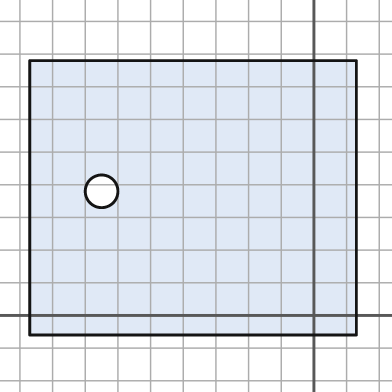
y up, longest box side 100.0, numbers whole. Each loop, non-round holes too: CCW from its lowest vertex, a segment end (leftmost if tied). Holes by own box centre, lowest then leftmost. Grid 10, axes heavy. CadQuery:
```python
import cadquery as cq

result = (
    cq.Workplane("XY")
    .moveTo(-87.0, -6.0)
    .lineTo(13.0, -6.0)
    .lineTo(13.0, 78.0)
    .lineTo(-87.0, 78.0)
    .close()
    .moveTo(-65.0, 38.0)
    .circle(5.0)
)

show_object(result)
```